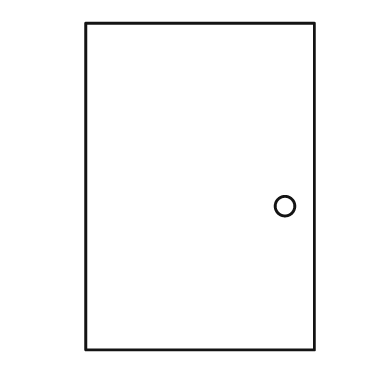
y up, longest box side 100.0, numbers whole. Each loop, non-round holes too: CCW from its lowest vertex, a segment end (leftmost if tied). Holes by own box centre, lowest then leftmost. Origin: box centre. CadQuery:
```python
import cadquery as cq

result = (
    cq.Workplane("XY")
    .moveTo(-35.0, -50.0)
    .lineTo(35.0, -50.0)
    .lineTo(35.0, 50.0)
    .lineTo(-35.0, 50.0)
    .close()
    .moveTo(26.0, -6.0)
    .circle(3.0)
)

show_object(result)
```